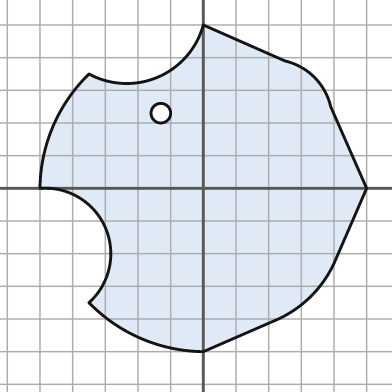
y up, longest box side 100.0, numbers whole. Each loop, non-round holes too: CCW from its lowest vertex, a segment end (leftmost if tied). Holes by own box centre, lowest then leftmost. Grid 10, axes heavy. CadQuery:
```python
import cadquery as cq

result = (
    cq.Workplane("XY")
    .moveTo(0.0, -50.0)
    .lineTo(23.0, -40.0)
    .threePointArc((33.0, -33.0), (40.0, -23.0))
    .lineTo(50.0, 0.0)
    .lineTo(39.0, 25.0)
    .threePointArc((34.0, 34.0), (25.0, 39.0))
    .lineTo(0.0, 50.0)
    .threePointArc((-14.0, 34.0), (-35.0, 35.0))
    .threePointArc((-46.0, 19.0), (-50.0, 0.0))
    .threePointArc((-30.0, -12.0), (-35.0, -35.0))
    .threePointArc((-19.0, -46.0), (0.0, -50.0))
    .close()
    .moveTo(-13.0, 23.0)
    .circle(3.0)
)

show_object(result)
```